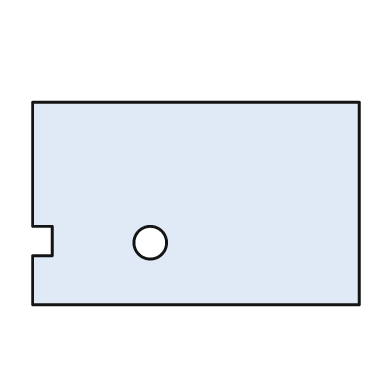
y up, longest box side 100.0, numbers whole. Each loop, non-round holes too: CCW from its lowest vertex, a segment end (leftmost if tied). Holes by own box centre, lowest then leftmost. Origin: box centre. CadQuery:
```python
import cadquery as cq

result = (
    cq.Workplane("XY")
    .moveTo(-50.0, -31.0)
    .lineTo(50.0, -31.0)
    .lineTo(50.0, 31.0)
    .lineTo(-50.0, 31.0)
    .lineTo(-50.0, -7.0)
    .lineTo(-44.0, -7.0)
    .lineTo(-44.0, -16.0)
    .lineTo(-50.0, -16.0)
    .close()
    .moveTo(-14.0, -12.0)
    .circle(5.0)
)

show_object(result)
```